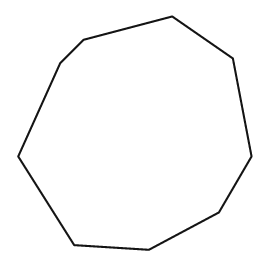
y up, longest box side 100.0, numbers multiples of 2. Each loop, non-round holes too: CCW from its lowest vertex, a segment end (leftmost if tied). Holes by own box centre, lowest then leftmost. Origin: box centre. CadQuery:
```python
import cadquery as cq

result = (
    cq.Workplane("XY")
    .moveTo(6.0, -50.0)
    .lineTo(36.0, -34.0)
    .lineTo(50.0, -10.0)
    .lineTo(42.0, 32.0)
    .lineTo(16.0, 50.0)
    .lineTo(-22.0, 40.0)
    .lineTo(-32.0, 30.0)
    .lineTo(-50.0, -10.0)
    .lineTo(-26.0, -48.0)
    .close()
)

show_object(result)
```